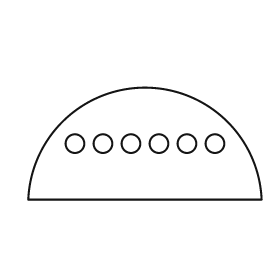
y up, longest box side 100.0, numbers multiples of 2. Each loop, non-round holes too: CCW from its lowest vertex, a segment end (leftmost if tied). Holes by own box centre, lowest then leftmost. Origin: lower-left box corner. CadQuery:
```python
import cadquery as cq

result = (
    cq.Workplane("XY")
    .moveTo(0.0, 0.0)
    .lineTo(100.0, 0.0)
    .threePointArc((50.0, 48.0), (0.0, 0.0))
    .close()
    .moveTo(20.0, 24.0)
    .circle(4.0)
    .moveTo(32.0, 24.0)
    .circle(4.0)
    .moveTo(44.0, 24.0)
    .circle(4.0)
    .moveTo(56.0, 24.0)
    .circle(4.0)
    .moveTo(68.0, 24.0)
    .circle(4.0)
    .moveTo(80.0, 24.0)
    .circle(4.0)
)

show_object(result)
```